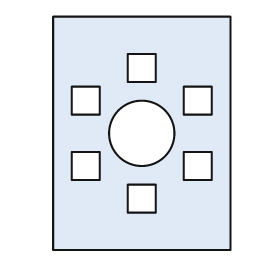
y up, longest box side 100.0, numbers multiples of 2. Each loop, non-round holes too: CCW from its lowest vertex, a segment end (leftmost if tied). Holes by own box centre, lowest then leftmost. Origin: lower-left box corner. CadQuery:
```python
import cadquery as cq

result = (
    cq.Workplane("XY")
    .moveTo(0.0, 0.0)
    .lineTo(76.0, 0.0)
    .lineTo(76.0, 100.0)
    .lineTo(0.0, 100.0)
    .close()
    .moveTo(32.0, 16.0)
    .lineTo(44.0, 16.0)
    .lineTo(44.0, 28.0)
    .lineTo(32.0, 28.0)
    .close()
    .moveTo(8.0, 30.0)
    .lineTo(20.0, 30.0)
    .lineTo(20.0, 42.0)
    .lineTo(8.0, 42.0)
    .close()
    .moveTo(56.0, 30.0)
    .lineTo(68.0, 30.0)
    .lineTo(68.0, 42.0)
    .lineTo(56.0, 42.0)
    .close()
    .moveTo(38.0, 50.0)
    .circle(14.0)
    .moveTo(8.0, 58.0)
    .lineTo(20.0, 58.0)
    .lineTo(20.0, 70.0)
    .lineTo(8.0, 70.0)
    .close()
    .moveTo(56.0, 58.0)
    .lineTo(68.0, 58.0)
    .lineTo(68.0, 70.0)
    .lineTo(56.0, 70.0)
    .close()
    .moveTo(32.0, 72.0)
    .lineTo(44.0, 72.0)
    .lineTo(44.0, 84.0)
    .lineTo(32.0, 84.0)
    .close()
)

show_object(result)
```